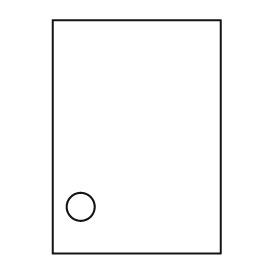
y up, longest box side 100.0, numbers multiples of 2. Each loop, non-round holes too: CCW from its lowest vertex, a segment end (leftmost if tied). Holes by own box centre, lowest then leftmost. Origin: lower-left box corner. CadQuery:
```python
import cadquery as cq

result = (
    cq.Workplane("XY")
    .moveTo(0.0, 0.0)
    .lineTo(72.0, 0.0)
    .lineTo(72.0, 100.0)
    .lineTo(0.0, 100.0)
    .close()
    .moveTo(12.0, 20.0)
    .circle(6.0)
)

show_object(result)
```